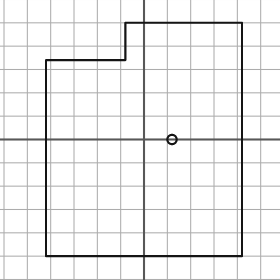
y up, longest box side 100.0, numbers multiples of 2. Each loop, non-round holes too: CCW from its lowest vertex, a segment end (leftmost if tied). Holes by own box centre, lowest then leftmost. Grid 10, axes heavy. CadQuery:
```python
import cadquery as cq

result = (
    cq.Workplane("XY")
    .moveTo(-42.0, -50.0)
    .lineTo(42.0, -50.0)
    .lineTo(42.0, 50.0)
    .lineTo(-8.0, 50.0)
    .lineTo(-8.0, 34.0)
    .lineTo(-42.0, 34.0)
    .close()
    .moveTo(12.0, 0.0)
    .circle(2.0)
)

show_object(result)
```